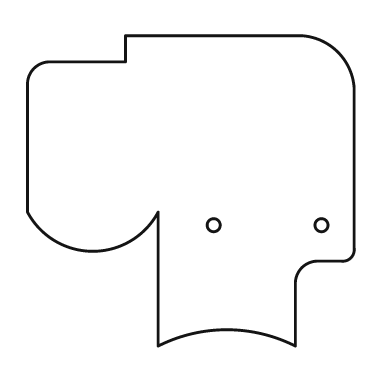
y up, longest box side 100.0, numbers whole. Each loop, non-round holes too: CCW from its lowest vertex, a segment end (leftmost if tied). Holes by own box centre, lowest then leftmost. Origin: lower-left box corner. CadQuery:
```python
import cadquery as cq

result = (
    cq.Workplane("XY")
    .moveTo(40.0, 0.0)
    .threePointArc((61.0, 5.0), (82.0, 0.0))
    .lineTo(82.0, 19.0)
    .threePointArc((84.0, 24.0), (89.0, 26.0))
    .lineTo(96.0, 26.0)
    .threePointArc((99.0, 27.0), (100.0, 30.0))
    .lineTo(100.0, 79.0)
    .threePointArc((95.0, 90.0), (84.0, 95.0))
    .lineTo(30.0, 95.0)
    .lineTo(30.0, 87.0)
    .lineTo(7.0, 87.0)
    .threePointArc((2.0, 85.0), (0.0, 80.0))
    .lineTo(0.0, 41.0)
    .threePointArc((20.0, 29.0), (40.0, 41.0))
    .close()
    .moveTo(57.0, 37.0)
    .circle(2.0)
    .moveTo(90.0, 37.0)
    .circle(2.0)
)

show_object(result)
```